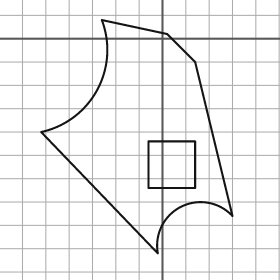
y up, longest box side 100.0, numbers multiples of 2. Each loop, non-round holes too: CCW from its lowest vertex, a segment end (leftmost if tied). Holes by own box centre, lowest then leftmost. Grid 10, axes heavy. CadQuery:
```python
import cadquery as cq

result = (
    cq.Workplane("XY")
    .moveTo(-2.0, -92.0)
    .threePointArc((8.0, -72.0), (30.0, -76.0))
    .lineTo(14.0, -10.0)
    .lineTo(2.0, 2.0)
    .lineTo(-26.0, 8.0)
    .threePointArc((-28.0, -22.0), (-52.0, -40.0))
    .close()
    .moveTo(-6.0, -64.0)
    .lineTo(14.0, -64.0)
    .lineTo(14.0, -44.0)
    .lineTo(-6.0, -44.0)
    .close()
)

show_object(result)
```